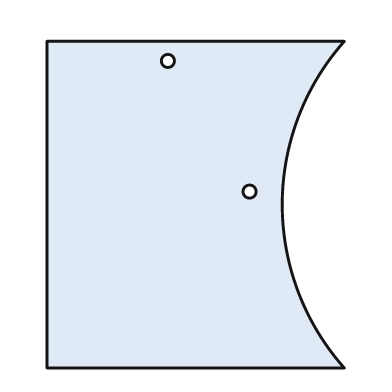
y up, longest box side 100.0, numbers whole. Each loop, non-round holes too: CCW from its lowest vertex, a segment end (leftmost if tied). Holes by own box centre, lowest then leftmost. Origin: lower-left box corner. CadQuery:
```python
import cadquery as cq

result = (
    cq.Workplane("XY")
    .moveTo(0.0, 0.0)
    .lineTo(91.0, 0.0)
    .threePointArc((72.0, 50.0), (91.0, 100.0))
    .lineTo(0.0, 100.0)
    .close()
    .moveTo(62.0, 54.0)
    .circle(2.0)
    .moveTo(37.0, 94.0)
    .circle(2.0)
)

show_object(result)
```